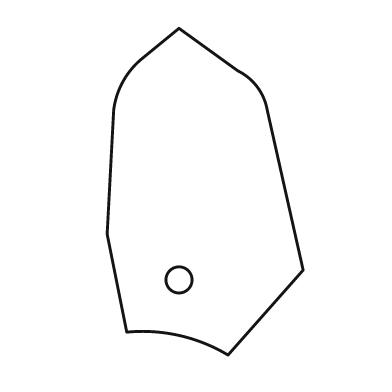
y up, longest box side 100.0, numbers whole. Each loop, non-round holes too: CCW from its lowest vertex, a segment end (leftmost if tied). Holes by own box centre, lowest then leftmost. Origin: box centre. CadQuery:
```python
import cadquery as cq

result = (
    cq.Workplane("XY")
    .moveTo(7.0, -50.0)
    .lineTo(30.0, -24.0)
    .lineTo(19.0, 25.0)
    .threePointArc((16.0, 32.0), (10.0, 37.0))
    .lineTo(-8.0, 50.0)
    .lineTo(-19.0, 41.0)
    .threePointArc((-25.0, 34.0), (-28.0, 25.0))
    .lineTo(-30.0, -13.0)
    .lineTo(-24.0, -43.0)
    .threePointArc((-8.0, -44.0), (7.0, -50.0))
    .close()
    .moveTo(-8.0, -27.0)
    .circle(4.0)
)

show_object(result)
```